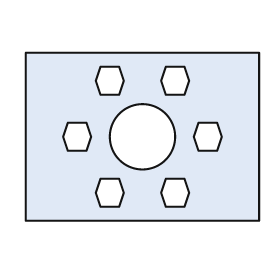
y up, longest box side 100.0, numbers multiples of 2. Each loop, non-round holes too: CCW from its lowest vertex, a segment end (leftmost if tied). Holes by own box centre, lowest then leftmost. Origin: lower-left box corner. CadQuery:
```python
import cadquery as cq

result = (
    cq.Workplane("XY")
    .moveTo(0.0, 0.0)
    .lineTo(100.0, 0.0)
    .lineTo(100.0, 72.0)
    .lineTo(0.0, 72.0)
    .close()
    .moveTo(32.0, 6.0)
    .lineTo(40.0, 6.0)
    .lineTo(42.0, 12.0)
    .lineTo(40.0, 18.0)
    .lineTo(32.0, 18.0)
    .lineTo(30.0, 12.0)
    .close()
    .moveTo(60.0, 6.0)
    .lineTo(68.0, 6.0)
    .lineTo(70.0, 12.0)
    .lineTo(68.0, 18.0)
    .lineTo(60.0, 18.0)
    .lineTo(58.0, 12.0)
    .close()
    .moveTo(18.0, 30.0)
    .lineTo(26.0, 30.0)
    .lineTo(28.0, 36.0)
    .lineTo(26.0, 42.0)
    .lineTo(18.0, 42.0)
    .lineTo(16.0, 36.0)
    .close()
    .moveTo(50.0, 36.0)
    .circle(14.0)
    .moveTo(74.0, 30.0)
    .lineTo(82.0, 30.0)
    .lineTo(84.0, 36.0)
    .lineTo(82.0, 42.0)
    .lineTo(74.0, 42.0)
    .lineTo(72.0, 36.0)
    .close()
    .moveTo(32.0, 54.0)
    .lineTo(40.0, 54.0)
    .lineTo(42.0, 60.0)
    .lineTo(40.0, 66.0)
    .lineTo(32.0, 66.0)
    .lineTo(30.0, 60.0)
    .close()
    .moveTo(60.0, 54.0)
    .lineTo(68.0, 54.0)
    .lineTo(70.0, 60.0)
    .lineTo(68.0, 66.0)
    .lineTo(60.0, 66.0)
    .lineTo(58.0, 60.0)
    .close()
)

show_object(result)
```